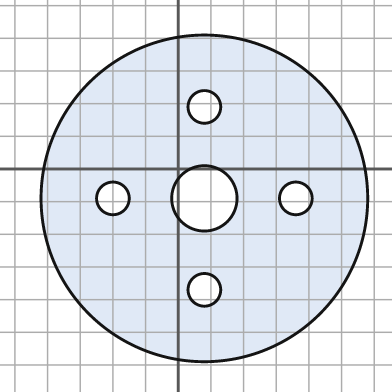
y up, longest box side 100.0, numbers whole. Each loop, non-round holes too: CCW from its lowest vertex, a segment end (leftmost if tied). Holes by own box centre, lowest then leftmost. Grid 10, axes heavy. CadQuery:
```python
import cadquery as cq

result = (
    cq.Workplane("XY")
    .moveTo(8.0, -9.0)
    .circle(50.0)
    .moveTo(8.0, -37.0)
    .circle(5.0)
    .moveTo(-20.0, -9.0)
    .circle(5.0)
    .moveTo(8.0, -9.0)
    .circle(10.0)
    .moveTo(36.0, -9.0)
    .circle(5.0)
    .moveTo(8.0, 19.0)
    .circle(5.0)
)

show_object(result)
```